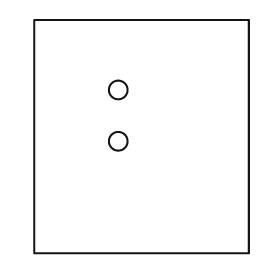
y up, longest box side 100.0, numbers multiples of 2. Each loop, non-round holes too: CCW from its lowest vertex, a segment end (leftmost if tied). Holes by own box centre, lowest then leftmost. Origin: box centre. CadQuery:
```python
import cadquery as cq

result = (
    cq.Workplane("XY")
    .moveTo(-46.0, -50.0)
    .lineTo(46.0, -50.0)
    .lineTo(46.0, 50.0)
    .lineTo(-46.0, 50.0)
    .close()
    .moveTo(-10.0, -2.0)
    .circle(4.0)
    .moveTo(-10.0, 20.0)
    .circle(4.0)
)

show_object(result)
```